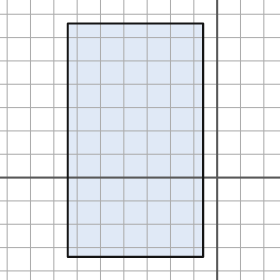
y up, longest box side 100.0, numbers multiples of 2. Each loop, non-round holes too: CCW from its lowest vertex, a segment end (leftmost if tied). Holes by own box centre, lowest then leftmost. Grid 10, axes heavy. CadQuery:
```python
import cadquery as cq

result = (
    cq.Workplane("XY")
    .moveTo(-64.0, -34.0)
    .lineTo(-6.0, -34.0)
    .lineTo(-6.0, 66.0)
    .lineTo(-64.0, 66.0)
    .close()
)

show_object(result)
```